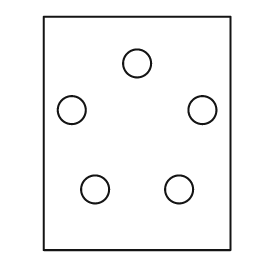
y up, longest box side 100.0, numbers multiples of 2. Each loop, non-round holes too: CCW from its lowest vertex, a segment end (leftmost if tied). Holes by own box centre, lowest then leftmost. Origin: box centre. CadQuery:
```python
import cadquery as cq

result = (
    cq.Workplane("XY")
    .moveTo(-40.0, -50.0)
    .lineTo(40.0, -50.0)
    .lineTo(40.0, 50.0)
    .lineTo(-40.0, 50.0)
    .close()
    .moveTo(-18.0, -24.0)
    .circle(6.0)
    .moveTo(18.0, -24.0)
    .circle(6.0)
    .moveTo(-28.0, 10.0)
    .circle(6.0)
    .moveTo(28.0, 10.0)
    .circle(6.0)
    .moveTo(0.0, 30.0)
    .circle(6.0)
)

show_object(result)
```